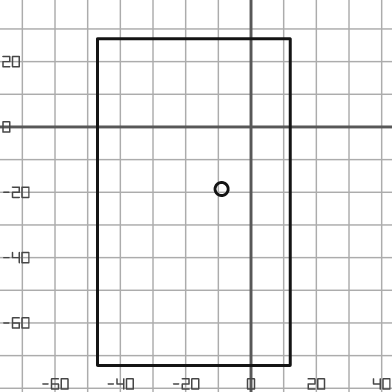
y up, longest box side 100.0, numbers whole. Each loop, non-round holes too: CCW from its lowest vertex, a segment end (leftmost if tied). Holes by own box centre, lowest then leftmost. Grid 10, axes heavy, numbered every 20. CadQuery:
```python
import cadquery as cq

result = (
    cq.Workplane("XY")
    .moveTo(-47.0, -73.0)
    .lineTo(12.0, -73.0)
    .lineTo(12.0, 27.0)
    .lineTo(-47.0, 27.0)
    .close()
    .moveTo(-9.0, -19.0)
    .circle(2.0)
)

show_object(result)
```